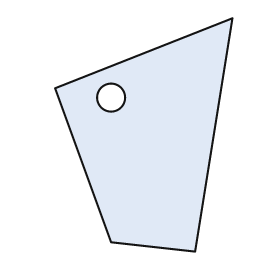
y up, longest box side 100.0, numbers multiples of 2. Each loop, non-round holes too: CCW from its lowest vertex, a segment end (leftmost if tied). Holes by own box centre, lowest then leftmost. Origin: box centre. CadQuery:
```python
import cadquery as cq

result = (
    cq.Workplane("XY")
    .moveTo(22.0, -50.0)
    .lineTo(38.0, 50.0)
    .lineTo(-38.0, 20.0)
    .lineTo(-14.0, -46.0)
    .close()
    .moveTo(-14.0, 16.0)
    .circle(6.0)
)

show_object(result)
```